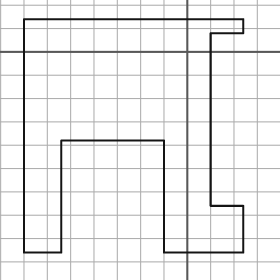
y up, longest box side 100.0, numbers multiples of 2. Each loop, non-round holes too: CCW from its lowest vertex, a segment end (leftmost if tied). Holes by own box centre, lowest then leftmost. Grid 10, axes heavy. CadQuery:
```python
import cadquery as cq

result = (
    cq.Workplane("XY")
    .moveTo(-70.0, -86.0)
    .lineTo(-54.0, -86.0)
    .lineTo(-54.0, -38.0)
    .lineTo(-10.0, -38.0)
    .lineTo(-10.0, -86.0)
    .lineTo(24.0, -86.0)
    .lineTo(24.0, -66.0)
    .lineTo(10.0, -66.0)
    .lineTo(10.0, 8.0)
    .lineTo(24.0, 8.0)
    .lineTo(24.0, 14.0)
    .lineTo(-70.0, 14.0)
    .close()
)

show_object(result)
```